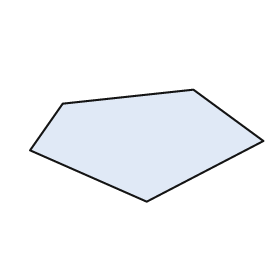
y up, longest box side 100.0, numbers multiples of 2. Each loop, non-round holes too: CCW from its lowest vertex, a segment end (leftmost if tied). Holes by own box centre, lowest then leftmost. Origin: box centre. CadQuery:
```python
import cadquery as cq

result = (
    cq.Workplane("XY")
    .moveTo(0.0, -24.0)
    .lineTo(50.0, 2.0)
    .lineTo(20.0, 24.0)
    .lineTo(-36.0, 18.0)
    .lineTo(-50.0, -2.0)
    .close()
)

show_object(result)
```